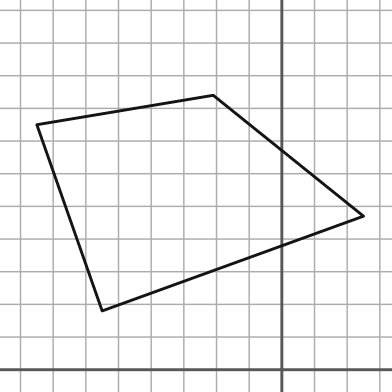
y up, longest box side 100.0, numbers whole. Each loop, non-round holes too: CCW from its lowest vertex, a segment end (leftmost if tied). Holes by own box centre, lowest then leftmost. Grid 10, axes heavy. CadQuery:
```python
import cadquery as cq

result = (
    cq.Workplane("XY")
    .moveTo(-55.0, 18.0)
    .lineTo(25.0, 47.0)
    .lineTo(-21.0, 84.0)
    .lineTo(-75.0, 75.0)
    .close()
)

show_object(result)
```